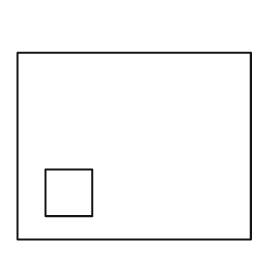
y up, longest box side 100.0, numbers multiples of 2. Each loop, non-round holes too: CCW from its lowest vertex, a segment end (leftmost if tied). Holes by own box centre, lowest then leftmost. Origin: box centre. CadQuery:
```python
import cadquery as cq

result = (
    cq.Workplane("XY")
    .moveTo(-50.0, -40.0)
    .lineTo(50.0, -40.0)
    .lineTo(50.0, 40.0)
    .lineTo(-50.0, 40.0)
    .close()
    .moveTo(-38.0, -30.0)
    .lineTo(-18.0, -30.0)
    .lineTo(-18.0, -10.0)
    .lineTo(-38.0, -10.0)
    .close()
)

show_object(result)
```